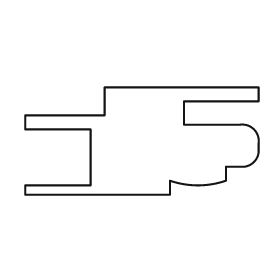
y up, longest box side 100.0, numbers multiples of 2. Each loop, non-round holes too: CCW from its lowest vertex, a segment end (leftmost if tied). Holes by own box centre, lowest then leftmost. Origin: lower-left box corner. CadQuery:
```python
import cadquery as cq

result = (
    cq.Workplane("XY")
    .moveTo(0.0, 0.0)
    .lineTo(62.0, 0.0)
    .lineTo(62.0, 6.0)
    .threePointArc((74.0, 4.0), (86.0, 6.0))
    .lineTo(86.0, 12.0)
    .lineTo(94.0, 12.0)
    .threePointArc((98.0, 14.0), (100.0, 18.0))
    .lineTo(100.0, 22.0)
    .threePointArc((98.0, 28.0), (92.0, 30.0))
    .lineTo(68.0, 30.0)
    .lineTo(68.0, 40.0)
    .lineTo(100.0, 40.0)
    .lineTo(100.0, 46.0)
    .lineTo(34.0, 46.0)
    .lineTo(34.0, 34.0)
    .lineTo(0.0, 34.0)
    .lineTo(0.0, 28.0)
    .lineTo(28.0, 28.0)
    .lineTo(28.0, 4.0)
    .lineTo(0.0, 4.0)
    .close()
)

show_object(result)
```